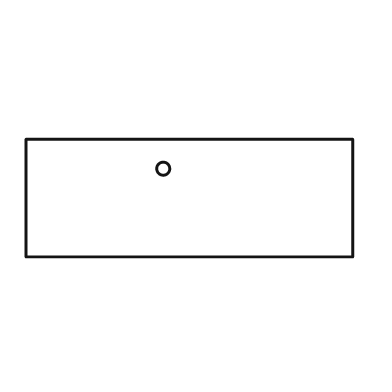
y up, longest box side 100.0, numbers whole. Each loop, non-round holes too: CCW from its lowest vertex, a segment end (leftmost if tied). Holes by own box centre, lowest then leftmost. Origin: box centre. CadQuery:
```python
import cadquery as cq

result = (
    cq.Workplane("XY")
    .moveTo(-50.0, -18.0)
    .lineTo(50.0, -18.0)
    .lineTo(50.0, 18.0)
    .lineTo(-50.0, 18.0)
    .close()
    .moveTo(-8.0, 9.0)
    .circle(2.0)
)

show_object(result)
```